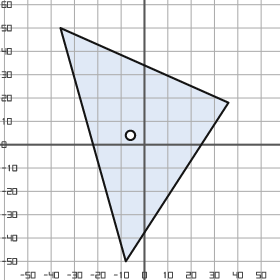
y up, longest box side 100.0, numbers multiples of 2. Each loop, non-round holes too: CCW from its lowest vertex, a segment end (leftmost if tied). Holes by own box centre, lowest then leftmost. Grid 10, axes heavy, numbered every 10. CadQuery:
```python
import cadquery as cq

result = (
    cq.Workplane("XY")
    .moveTo(-8.0, -50.0)
    .lineTo(36.0, 18.0)
    .lineTo(-36.0, 50.0)
    .close()
    .moveTo(-6.0, 4.0)
    .circle(2.0)
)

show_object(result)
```